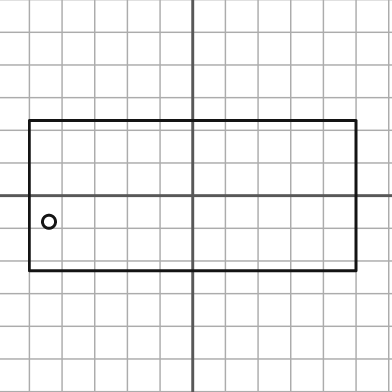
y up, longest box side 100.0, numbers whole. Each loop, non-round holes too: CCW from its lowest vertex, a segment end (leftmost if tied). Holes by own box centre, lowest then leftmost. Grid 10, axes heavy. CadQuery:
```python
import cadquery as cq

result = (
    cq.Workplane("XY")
    .moveTo(-50.0, -23.0)
    .lineTo(50.0, -23.0)
    .lineTo(50.0, 23.0)
    .lineTo(-50.0, 23.0)
    .close()
    .moveTo(-44.0, -8.0)
    .circle(2.0)
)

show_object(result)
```